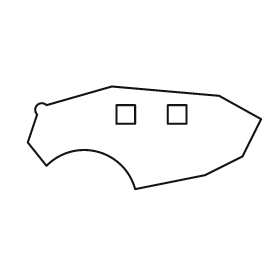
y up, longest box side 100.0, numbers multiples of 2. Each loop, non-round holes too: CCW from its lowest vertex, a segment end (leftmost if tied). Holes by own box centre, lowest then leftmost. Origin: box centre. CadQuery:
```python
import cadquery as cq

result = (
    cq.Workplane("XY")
    .moveTo(-4.0, -22.0)
    .lineTo(26.0, -16.0)
    .lineTo(42.0, -8.0)
    .lineTo(50.0, 8.0)
    .lineTo(32.0, 18.0)
    .lineTo(-14.0, 22.0)
    .lineTo(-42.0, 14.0)
    .threePointArc((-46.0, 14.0), (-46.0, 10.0))
    .lineTo(-50.0, -2.0)
    .lineTo(-42.0, -12.0)
    .threePointArc((-20.0, -6.0), (-4.0, -22.0))
    .close()
    .moveTo(-12.0, 6.0)
    .lineTo(-4.0, 6.0)
    .lineTo(-4.0, 14.0)
    .lineTo(-12.0, 14.0)
    .close()
    .moveTo(10.0, 6.0)
    .lineTo(18.0, 6.0)
    .lineTo(18.0, 14.0)
    .lineTo(10.0, 14.0)
    .close()
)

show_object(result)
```